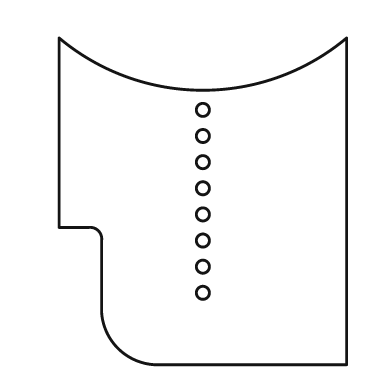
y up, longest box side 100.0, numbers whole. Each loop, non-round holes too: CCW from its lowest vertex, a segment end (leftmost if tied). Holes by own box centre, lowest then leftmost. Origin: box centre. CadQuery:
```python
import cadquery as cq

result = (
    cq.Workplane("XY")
    .moveTo(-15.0, -50.0)
    .lineTo(44.0, -50.0)
    .lineTo(44.0, 50.0)
    .threePointArc((0.0, 34.0), (-44.0, 50.0))
    .lineTo(-44.0, -8.0)
    .lineTo(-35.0, -8.0)
    .threePointArc((-32.0, -9.0), (-31.0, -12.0))
    .lineTo(-31.0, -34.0)
    .threePointArc((-26.0, -45.0), (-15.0, -50.0))
    .close()
    .moveTo(0.0, -28.0)
    .circle(2.0)
    .moveTo(0.0, -20.0)
    .circle(2.0)
    .moveTo(0.0, -12.0)
    .circle(2.0)
    .moveTo(0.0, -4.0)
    .circle(2.0)
    .moveTo(0.0, 4.0)
    .circle(2.0)
    .moveTo(0.0, 12.0)
    .circle(2.0)
    .moveTo(0.0, 20.0)
    .circle(2.0)
    .moveTo(0.0, 28.0)
    .circle(2.0)
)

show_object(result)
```